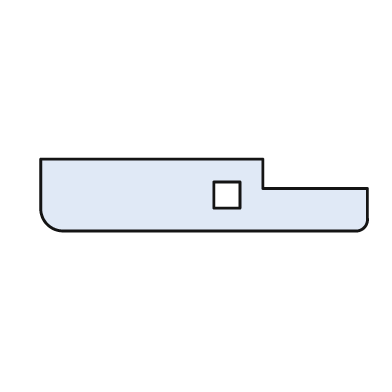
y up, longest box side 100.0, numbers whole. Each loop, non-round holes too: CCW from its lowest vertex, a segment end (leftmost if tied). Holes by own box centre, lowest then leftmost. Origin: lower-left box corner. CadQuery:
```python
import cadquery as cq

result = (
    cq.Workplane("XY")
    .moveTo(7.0, 0.0)
    .lineTo(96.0, 0.0)
    .threePointArc((99.0, 1.0), (100.0, 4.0))
    .lineTo(100.0, 13.0)
    .lineTo(68.0, 13.0)
    .lineTo(68.0, 22.0)
    .lineTo(0.0, 22.0)
    .lineTo(0.0, 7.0)
    .threePointArc((2.0, 2.0), (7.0, 0.0))
    .close()
    .moveTo(53.0, 7.0)
    .lineTo(61.0, 7.0)
    .lineTo(61.0, 15.0)
    .lineTo(53.0, 15.0)
    .close()
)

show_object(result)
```